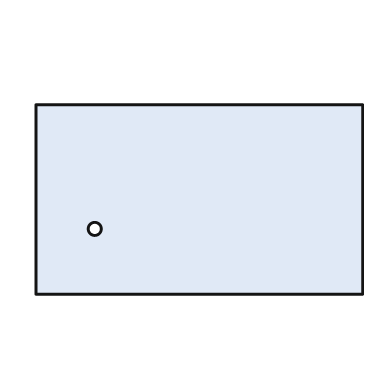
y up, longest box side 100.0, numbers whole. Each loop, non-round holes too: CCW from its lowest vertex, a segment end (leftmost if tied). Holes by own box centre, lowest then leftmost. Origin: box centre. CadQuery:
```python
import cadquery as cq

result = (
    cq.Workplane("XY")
    .moveTo(-50.0, -29.0)
    .lineTo(50.0, -29.0)
    .lineTo(50.0, 29.0)
    .lineTo(-50.0, 29.0)
    .close()
    .moveTo(-32.0, -9.0)
    .circle(2.0)
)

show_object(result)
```